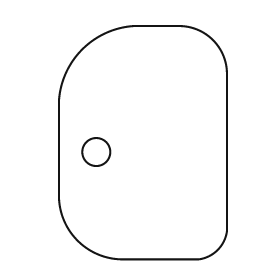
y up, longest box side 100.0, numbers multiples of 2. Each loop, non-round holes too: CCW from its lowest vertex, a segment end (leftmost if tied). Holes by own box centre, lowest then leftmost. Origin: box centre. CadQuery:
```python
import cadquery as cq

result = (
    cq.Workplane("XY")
    .moveTo(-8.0, -50.0)
    .lineTo(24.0, -50.0)
    .threePointArc((32.0, -46.0), (36.0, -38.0))
    .lineTo(36.0, 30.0)
    .threePointArc((30.0, 44.0), (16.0, 50.0))
    .lineTo(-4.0, 50.0)
    .threePointArc((-26.0, 40.0), (-36.0, 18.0))
    .lineTo(-36.0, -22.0)
    .threePointArc((-28.0, -42.0), (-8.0, -50.0))
    .close()
    .moveTo(-20.0, -4.0)
    .circle(6.0)
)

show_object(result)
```